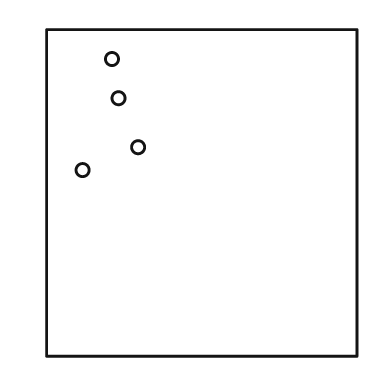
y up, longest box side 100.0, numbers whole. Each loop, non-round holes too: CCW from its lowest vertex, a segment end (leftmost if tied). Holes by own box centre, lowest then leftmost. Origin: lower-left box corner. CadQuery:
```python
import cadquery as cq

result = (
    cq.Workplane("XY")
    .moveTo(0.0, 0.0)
    .lineTo(95.0, 0.0)
    .lineTo(95.0, 100.0)
    .lineTo(0.0, 100.0)
    .close()
    .moveTo(11.0, 57.0)
    .circle(2.0)
    .moveTo(28.0, 64.0)
    .circle(2.0)
    .moveTo(22.0, 79.0)
    .circle(2.0)
    .moveTo(20.0, 91.0)
    .circle(2.0)
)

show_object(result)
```